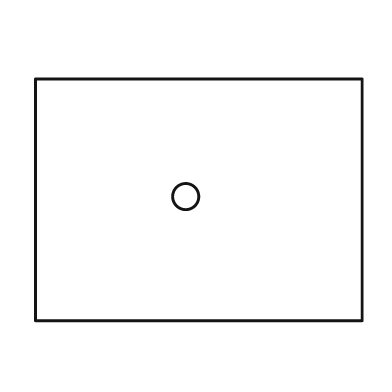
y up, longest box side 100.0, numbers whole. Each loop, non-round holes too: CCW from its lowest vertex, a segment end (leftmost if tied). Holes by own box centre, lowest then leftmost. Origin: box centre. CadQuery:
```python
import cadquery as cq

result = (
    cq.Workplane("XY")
    .moveTo(-50.0, -37.0)
    .lineTo(50.0, -37.0)
    .lineTo(50.0, 37.0)
    .lineTo(-50.0, 37.0)
    .close()
    .moveTo(-4.0, 1.0)
    .circle(4.0)
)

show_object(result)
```